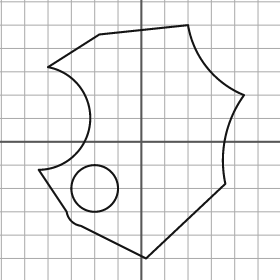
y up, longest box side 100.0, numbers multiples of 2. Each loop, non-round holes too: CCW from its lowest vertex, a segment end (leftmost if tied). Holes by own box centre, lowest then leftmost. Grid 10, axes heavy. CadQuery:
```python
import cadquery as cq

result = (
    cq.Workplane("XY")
    .moveTo(2.0, -50.0)
    .lineTo(36.0, -18.0)
    .threePointArc((36.0, 2.0), (44.0, 20.0))
    .threePointArc((28.0, 32.0), (20.0, 50.0))
    .lineTo(-18.0, 46.0)
    .lineTo(-40.0, 32.0)
    .threePointArc((-22.0, 8.0), (-44.0, -12.0))
    .lineTo(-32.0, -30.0)
    .threePointArc((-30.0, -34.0), (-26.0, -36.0))
    .close()
    .moveTo(-20.0, -20.0)
    .circle(10.0)
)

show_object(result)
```